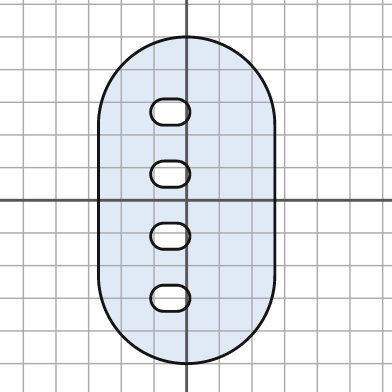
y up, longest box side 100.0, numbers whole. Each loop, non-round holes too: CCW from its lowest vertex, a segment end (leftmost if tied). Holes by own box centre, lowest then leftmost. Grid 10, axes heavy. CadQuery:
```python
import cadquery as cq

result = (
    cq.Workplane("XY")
    .moveTo(-27.0, -23.0)
    .threePointArc((0.0, -50.0), (27.0, -23.0))
    .lineTo(27.0, 23.0)
    .threePointArc((0.0, 50.0), (-27.0, 23.0))
    .close()
    .moveTo(-7.0, -34.0)
    .lineTo(-3.0, -34.0)
    .threePointArc((1.0, -30.0), (-3.0, -26.0))
    .lineTo(-7.0, -26.0)
    .threePointArc((-11.0, -30.0), (-7.0, -34.0))
    .close()
    .moveTo(-7.0, -15.0)
    .lineTo(-3.0, -15.0)
    .threePointArc((1.0, -11.0), (-3.0, -7.0))
    .lineTo(-7.0, -7.0)
    .threePointArc((-11.0, -11.0), (-7.0, -15.0))
    .close()
    .moveTo(-7.0, 4.0)
    .lineTo(-3.0, 4.0)
    .threePointArc((1.0, 8.0), (-3.0, 12.0))
    .lineTo(-7.0, 12.0)
    .threePointArc((-11.0, 8.0), (-7.0, 4.0))
    .close()
    .moveTo(-7.0, 23.0)
    .lineTo(-3.0, 23.0)
    .threePointArc((1.0, 27.0), (-3.0, 31.0))
    .lineTo(-7.0, 31.0)
    .threePointArc((-11.0, 27.0), (-7.0, 23.0))
    .close()
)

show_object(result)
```